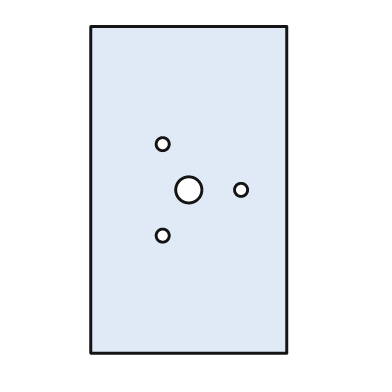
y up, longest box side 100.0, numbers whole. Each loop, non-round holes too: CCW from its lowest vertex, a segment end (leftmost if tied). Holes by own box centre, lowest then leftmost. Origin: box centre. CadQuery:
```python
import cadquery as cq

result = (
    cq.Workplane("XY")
    .moveTo(-30.0, -50.0)
    .lineTo(30.0, -50.0)
    .lineTo(30.0, 50.0)
    .lineTo(-30.0, 50.0)
    .close()
    .moveTo(-8.0, -14.0)
    .circle(2.0)
    .moveTo(0.0, 0.0)
    .circle(4.0)
    .moveTo(16.0, 0.0)
    .circle(2.0)
    .moveTo(-8.0, 14.0)
    .circle(2.0)
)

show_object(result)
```